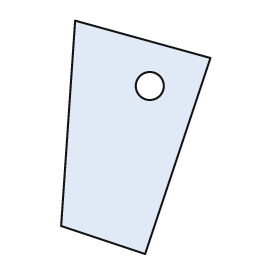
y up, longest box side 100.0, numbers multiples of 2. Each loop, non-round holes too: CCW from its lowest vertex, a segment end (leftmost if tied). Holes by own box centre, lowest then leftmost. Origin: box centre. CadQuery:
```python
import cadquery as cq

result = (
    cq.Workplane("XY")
    .moveTo(4.0, -50.0)
    .lineTo(32.0, 34.0)
    .lineTo(-26.0, 50.0)
    .lineTo(-32.0, -38.0)
    .close()
    .moveTo(6.0, 22.0)
    .circle(6.0)
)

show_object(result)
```